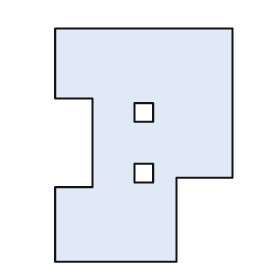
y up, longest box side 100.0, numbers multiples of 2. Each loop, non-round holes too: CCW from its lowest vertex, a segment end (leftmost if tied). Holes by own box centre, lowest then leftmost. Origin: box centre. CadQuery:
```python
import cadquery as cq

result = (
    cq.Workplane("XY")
    .moveTo(-38.0, -50.0)
    .lineTo(14.0, -50.0)
    .lineTo(14.0, -14.0)
    .lineTo(38.0, -14.0)
    .lineTo(38.0, 50.0)
    .lineTo(-38.0, 50.0)
    .lineTo(-38.0, 20.0)
    .lineTo(-22.0, 20.0)
    .lineTo(-22.0, -18.0)
    .lineTo(-38.0, -18.0)
    .close()
    .moveTo(-4.0, -16.0)
    .lineTo(4.0, -16.0)
    .lineTo(4.0, -8.0)
    .lineTo(-4.0, -8.0)
    .close()
    .moveTo(-4.0, 10.0)
    .lineTo(4.0, 10.0)
    .lineTo(4.0, 18.0)
    .lineTo(-4.0, 18.0)
    .close()
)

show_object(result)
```